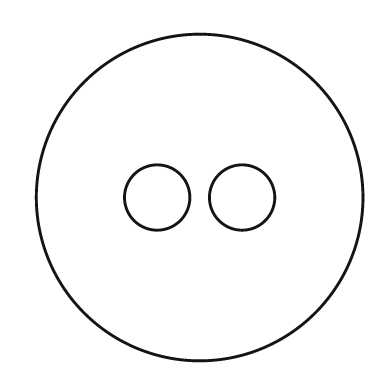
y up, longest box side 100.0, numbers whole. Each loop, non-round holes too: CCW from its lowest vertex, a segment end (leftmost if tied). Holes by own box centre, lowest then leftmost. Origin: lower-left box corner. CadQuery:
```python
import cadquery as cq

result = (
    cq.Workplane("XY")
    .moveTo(50.0, 50.0)
    .circle(50.0)
    .moveTo(37.0, 50.0)
    .circle(10.0)
    .moveTo(63.0, 50.0)
    .circle(10.0)
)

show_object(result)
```